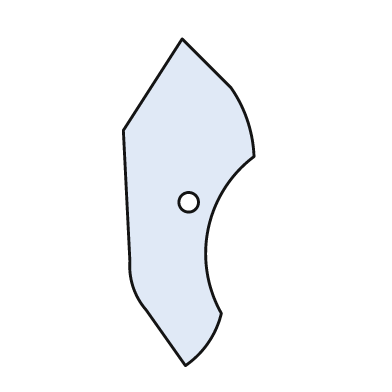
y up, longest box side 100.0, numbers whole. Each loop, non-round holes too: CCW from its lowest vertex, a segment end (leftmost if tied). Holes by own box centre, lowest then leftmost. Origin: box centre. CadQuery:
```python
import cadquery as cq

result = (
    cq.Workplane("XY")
    .moveTo(-1.0, -50.0)
    .threePointArc((6.0, -43.0), (10.0, -34.0))
    .threePointArc((6.0, -8.0), (20.0, 14.0))
    .threePointArc((18.0, 25.0), (13.0, 35.0))
    .lineTo(-2.0, 50.0)
    .lineTo(-20.0, 22.0)
    .lineTo(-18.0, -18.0)
    .threePointArc((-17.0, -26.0), (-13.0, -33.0))
    .close()
    .moveTo(0.0, 0.0)
    .circle(3.0)
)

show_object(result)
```